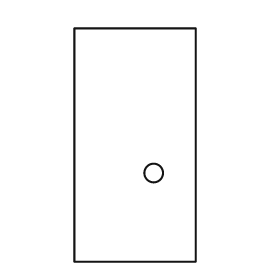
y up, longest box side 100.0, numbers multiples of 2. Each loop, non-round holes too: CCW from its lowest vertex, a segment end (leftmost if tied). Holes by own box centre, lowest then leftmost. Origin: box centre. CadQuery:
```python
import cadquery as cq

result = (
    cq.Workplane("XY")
    .moveTo(-26.0, -50.0)
    .lineTo(26.0, -50.0)
    .lineTo(26.0, 50.0)
    .lineTo(-26.0, 50.0)
    .close()
    .moveTo(8.0, -12.0)
    .circle(4.0)
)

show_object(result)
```